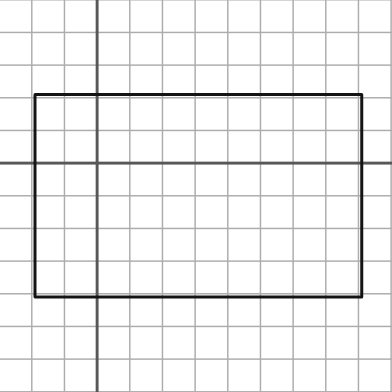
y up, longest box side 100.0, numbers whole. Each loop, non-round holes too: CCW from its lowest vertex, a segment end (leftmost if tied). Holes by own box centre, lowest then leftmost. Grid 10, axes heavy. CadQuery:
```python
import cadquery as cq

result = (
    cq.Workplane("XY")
    .moveTo(-19.0, -41.0)
    .lineTo(81.0, -41.0)
    .lineTo(81.0, 21.0)
    .lineTo(-19.0, 21.0)
    .close()
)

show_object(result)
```